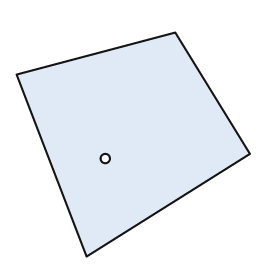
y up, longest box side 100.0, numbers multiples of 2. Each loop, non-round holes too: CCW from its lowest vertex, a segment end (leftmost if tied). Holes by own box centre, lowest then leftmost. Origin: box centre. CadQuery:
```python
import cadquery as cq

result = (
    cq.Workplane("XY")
    .moveTo(-20.0, -48.0)
    .lineTo(50.0, -4.0)
    .lineTo(18.0, 48.0)
    .lineTo(-50.0, 30.0)
    .close()
    .moveTo(-12.0, -6.0)
    .circle(2.0)
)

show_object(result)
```